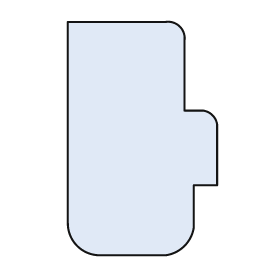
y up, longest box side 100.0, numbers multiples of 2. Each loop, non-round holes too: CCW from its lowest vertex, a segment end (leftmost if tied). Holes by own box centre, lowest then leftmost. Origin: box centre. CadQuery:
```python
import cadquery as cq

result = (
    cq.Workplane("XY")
    .moveTo(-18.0, -50.0)
    .lineTo(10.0, -50.0)
    .threePointArc((18.0, -46.0), (22.0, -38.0))
    .lineTo(22.0, -20.0)
    .lineTo(32.0, -20.0)
    .lineTo(32.0, 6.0)
    .threePointArc((30.0, 10.0), (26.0, 12.0))
    .lineTo(18.0, 12.0)
    .lineTo(18.0, 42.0)
    .threePointArc((16.0, 48.0), (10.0, 50.0))
    .lineTo(-32.0, 50.0)
    .lineTo(-32.0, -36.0)
    .threePointArc((-28.0, -46.0), (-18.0, -50.0))
    .close()
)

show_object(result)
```